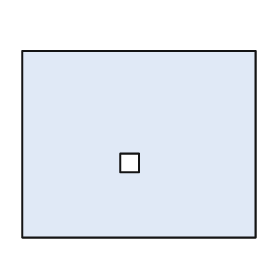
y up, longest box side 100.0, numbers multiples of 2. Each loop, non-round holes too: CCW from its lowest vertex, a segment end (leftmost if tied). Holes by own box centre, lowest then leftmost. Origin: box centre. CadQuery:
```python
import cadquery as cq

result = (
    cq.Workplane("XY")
    .moveTo(-50.0, -40.0)
    .lineTo(50.0, -40.0)
    .lineTo(50.0, 40.0)
    .lineTo(-50.0, 40.0)
    .close()
    .moveTo(-8.0, -12.0)
    .lineTo(0.0, -12.0)
    .lineTo(0.0, -4.0)
    .lineTo(-8.0, -4.0)
    .close()
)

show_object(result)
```